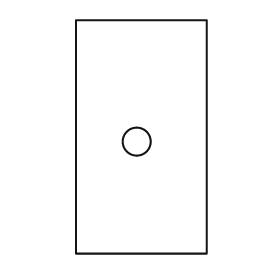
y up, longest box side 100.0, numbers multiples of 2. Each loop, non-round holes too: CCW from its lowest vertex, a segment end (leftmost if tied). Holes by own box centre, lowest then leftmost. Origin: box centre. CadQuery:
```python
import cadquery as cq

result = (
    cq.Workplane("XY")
    .moveTo(-28.0, -50.0)
    .lineTo(28.0, -50.0)
    .lineTo(28.0, 50.0)
    .lineTo(-28.0, 50.0)
    .close()
    .moveTo(-2.0, -2.0)
    .circle(6.0)
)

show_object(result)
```